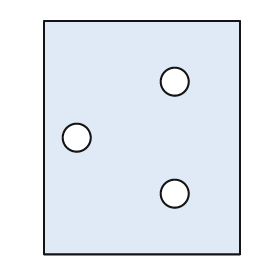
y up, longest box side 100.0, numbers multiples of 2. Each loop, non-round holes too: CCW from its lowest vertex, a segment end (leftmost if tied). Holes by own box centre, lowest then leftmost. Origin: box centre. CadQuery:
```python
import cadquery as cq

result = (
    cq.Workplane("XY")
    .moveTo(-42.0, -50.0)
    .lineTo(42.0, -50.0)
    .lineTo(42.0, 50.0)
    .lineTo(-42.0, 50.0)
    .close()
    .moveTo(14.0, -24.0)
    .circle(6.0)
    .moveTo(-28.0, 0.0)
    .circle(6.0)
    .moveTo(14.0, 24.0)
    .circle(6.0)
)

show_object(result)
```